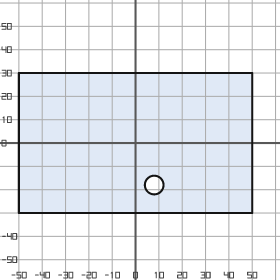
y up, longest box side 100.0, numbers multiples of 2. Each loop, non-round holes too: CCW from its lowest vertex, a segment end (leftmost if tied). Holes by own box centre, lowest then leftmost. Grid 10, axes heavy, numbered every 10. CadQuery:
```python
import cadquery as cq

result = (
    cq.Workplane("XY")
    .moveTo(-50.0, -30.0)
    .lineTo(50.0, -30.0)
    .lineTo(50.0, 30.0)
    .lineTo(-50.0, 30.0)
    .close()
    .moveTo(8.0, -18.0)
    .circle(4.0)
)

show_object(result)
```